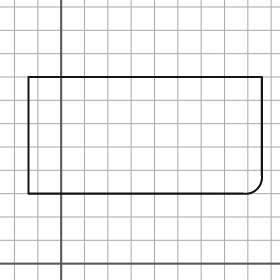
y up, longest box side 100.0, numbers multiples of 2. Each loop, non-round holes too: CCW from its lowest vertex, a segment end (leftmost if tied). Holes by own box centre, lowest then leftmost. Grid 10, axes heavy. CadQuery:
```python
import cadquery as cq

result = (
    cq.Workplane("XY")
    .moveTo(-14.0, 30.0)
    .lineTo(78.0, 30.0)
    .threePointArc((84.0, 32.0), (86.0, 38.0))
    .lineTo(86.0, 80.0)
    .lineTo(-14.0, 80.0)
    .close()
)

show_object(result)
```